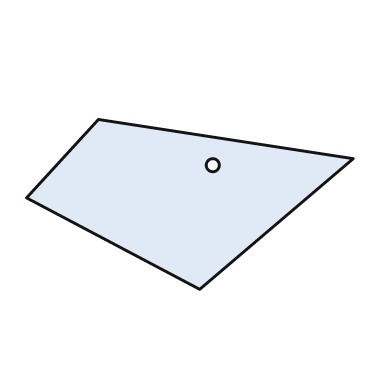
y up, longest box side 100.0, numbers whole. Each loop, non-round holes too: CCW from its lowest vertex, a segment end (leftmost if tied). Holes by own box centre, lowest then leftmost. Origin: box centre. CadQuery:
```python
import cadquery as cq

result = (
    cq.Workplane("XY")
    .moveTo(3.0, -26.0)
    .lineTo(50.0, 14.0)
    .lineTo(-28.0, 26.0)
    .lineTo(-50.0, 2.0)
    .close()
    .moveTo(7.0, 12.0)
    .circle(2.0)
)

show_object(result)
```